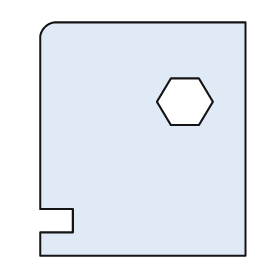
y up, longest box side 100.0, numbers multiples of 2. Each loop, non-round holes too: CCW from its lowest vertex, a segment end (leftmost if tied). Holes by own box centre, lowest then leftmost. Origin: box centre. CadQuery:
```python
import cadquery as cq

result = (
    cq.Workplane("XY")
    .moveTo(-44.0, -50.0)
    .lineTo(44.0, -50.0)
    .lineTo(44.0, 50.0)
    .lineTo(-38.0, 50.0)
    .threePointArc((-42.0, 48.0), (-44.0, 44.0))
    .lineTo(-44.0, -30.0)
    .lineTo(-30.0, -30.0)
    .lineTo(-30.0, -40.0)
    .lineTo(-44.0, -40.0)
    .close()
    .moveTo(12.0, 6.0)
    .lineTo(24.0, 6.0)
    .lineTo(30.0, 16.0)
    .lineTo(24.0, 26.0)
    .lineTo(12.0, 26.0)
    .lineTo(6.0, 16.0)
    .close()
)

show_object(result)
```